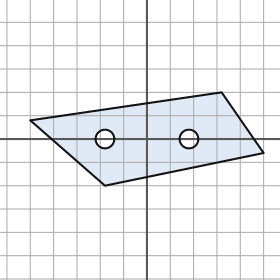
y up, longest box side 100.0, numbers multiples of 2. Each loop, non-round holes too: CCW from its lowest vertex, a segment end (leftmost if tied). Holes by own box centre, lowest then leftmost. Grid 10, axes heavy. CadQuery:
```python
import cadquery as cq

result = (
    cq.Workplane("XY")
    .moveTo(-18.0, -20.0)
    .lineTo(50.0, -6.0)
    .lineTo(32.0, 20.0)
    .lineTo(-50.0, 8.0)
    .close()
    .moveTo(-18.0, 0.0)
    .circle(4.0)
    .moveTo(18.0, 0.0)
    .circle(4.0)
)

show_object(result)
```